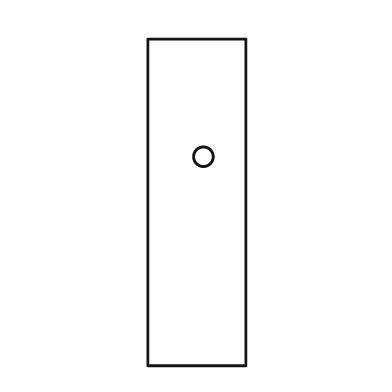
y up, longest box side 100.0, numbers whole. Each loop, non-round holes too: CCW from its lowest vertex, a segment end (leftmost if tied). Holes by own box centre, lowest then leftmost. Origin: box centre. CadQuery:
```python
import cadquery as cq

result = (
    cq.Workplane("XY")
    .moveTo(-15.0, -50.0)
    .lineTo(15.0, -50.0)
    .lineTo(15.0, 50.0)
    .lineTo(-15.0, 50.0)
    .close()
    .moveTo(2.0, 14.0)
    .circle(3.0)
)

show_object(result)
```